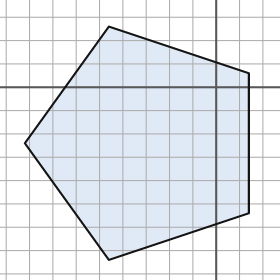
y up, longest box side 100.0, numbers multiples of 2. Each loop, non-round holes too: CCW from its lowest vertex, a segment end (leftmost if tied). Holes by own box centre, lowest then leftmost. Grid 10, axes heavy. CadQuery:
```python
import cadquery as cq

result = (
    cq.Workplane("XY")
    .moveTo(-46.0, -74.0)
    .lineTo(14.0, -54.0)
    .lineTo(14.0, 6.0)
    .lineTo(-46.0, 26.0)
    .lineTo(-82.0, -24.0)
    .close()
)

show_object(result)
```